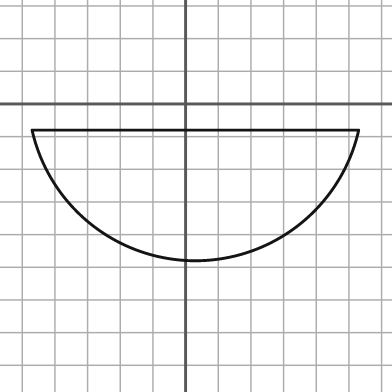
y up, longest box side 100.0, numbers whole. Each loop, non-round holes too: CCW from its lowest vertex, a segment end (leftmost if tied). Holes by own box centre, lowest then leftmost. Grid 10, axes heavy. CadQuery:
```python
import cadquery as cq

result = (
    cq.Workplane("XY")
    .moveTo(-47.0, -8.0)
    .threePointArc((3.0, -48.0), (53.0, -8.0))
    .close()
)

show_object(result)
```